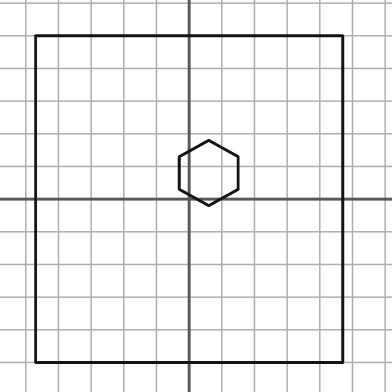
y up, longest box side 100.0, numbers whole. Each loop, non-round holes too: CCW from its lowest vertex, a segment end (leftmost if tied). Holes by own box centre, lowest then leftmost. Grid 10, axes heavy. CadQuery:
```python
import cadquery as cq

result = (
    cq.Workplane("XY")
    .moveTo(-47.0, -50.0)
    .lineTo(47.0, -50.0)
    .lineTo(47.0, 50.0)
    .lineTo(-47.0, 50.0)
    .close()
    .moveTo(6.0, -2.0)
    .lineTo(15.0, 3.0)
    .lineTo(15.0, 13.0)
    .lineTo(6.0, 18.0)
    .lineTo(-3.0, 13.0)
    .lineTo(-3.0, 3.0)
    .close()
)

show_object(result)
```